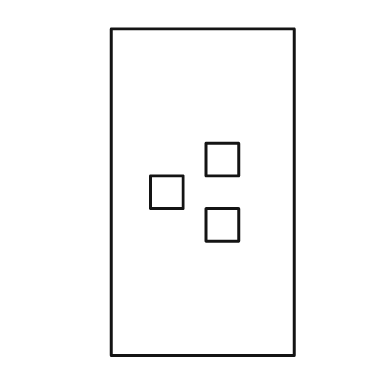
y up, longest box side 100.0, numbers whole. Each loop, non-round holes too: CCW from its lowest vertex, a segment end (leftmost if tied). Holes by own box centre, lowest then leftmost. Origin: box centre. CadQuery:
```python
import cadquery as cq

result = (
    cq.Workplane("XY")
    .moveTo(-28.0, -50.0)
    .lineTo(28.0, -50.0)
    .lineTo(28.0, 50.0)
    .lineTo(-28.0, 50.0)
    .close()
    .moveTo(1.0, -15.0)
    .lineTo(11.0, -15.0)
    .lineTo(11.0, -5.0)
    .lineTo(1.0, -5.0)
    .close()
    .moveTo(-16.0, -5.0)
    .lineTo(-6.0, -5.0)
    .lineTo(-6.0, 5.0)
    .lineTo(-16.0, 5.0)
    .close()
    .moveTo(1.0, 5.0)
    .lineTo(11.0, 5.0)
    .lineTo(11.0, 15.0)
    .lineTo(1.0, 15.0)
    .close()
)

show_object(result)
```